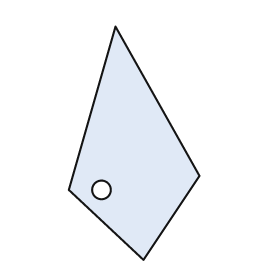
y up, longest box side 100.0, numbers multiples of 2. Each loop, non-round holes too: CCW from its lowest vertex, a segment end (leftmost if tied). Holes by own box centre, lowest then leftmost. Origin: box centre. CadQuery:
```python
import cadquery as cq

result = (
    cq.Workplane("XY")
    .moveTo(4.0, -50.0)
    .lineTo(28.0, -14.0)
    .lineTo(-8.0, 50.0)
    .lineTo(-28.0, -20.0)
    .close()
    .moveTo(-14.0, -20.0)
    .circle(4.0)
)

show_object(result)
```